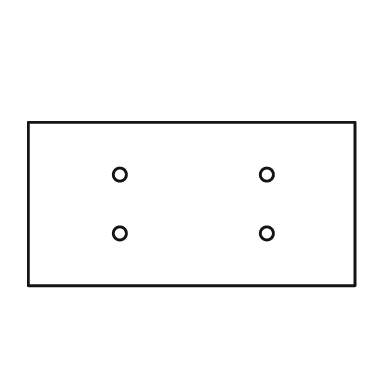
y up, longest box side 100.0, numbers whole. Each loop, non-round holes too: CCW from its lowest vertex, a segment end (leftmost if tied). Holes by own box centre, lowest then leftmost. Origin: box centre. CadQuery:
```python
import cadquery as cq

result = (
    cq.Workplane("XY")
    .moveTo(-50.0, -25.0)
    .lineTo(50.0, -25.0)
    .lineTo(50.0, 25.0)
    .lineTo(-50.0, 25.0)
    .close()
    .moveTo(-22.0, -9.0)
    .circle(2.0)
    .moveTo(23.0, -9.0)
    .circle(2.0)
    .moveTo(-22.0, 9.0)
    .circle(2.0)
    .moveTo(23.0, 9.0)
    .circle(2.0)
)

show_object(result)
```